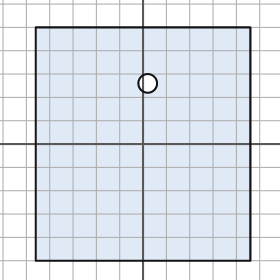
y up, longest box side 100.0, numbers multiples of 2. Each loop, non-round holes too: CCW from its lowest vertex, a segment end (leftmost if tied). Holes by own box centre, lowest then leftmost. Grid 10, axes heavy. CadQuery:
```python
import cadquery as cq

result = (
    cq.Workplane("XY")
    .moveTo(-46.0, -50.0)
    .lineTo(46.0, -50.0)
    .lineTo(46.0, 50.0)
    .lineTo(-46.0, 50.0)
    .close()
    .moveTo(2.0, 26.0)
    .circle(4.0)
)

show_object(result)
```